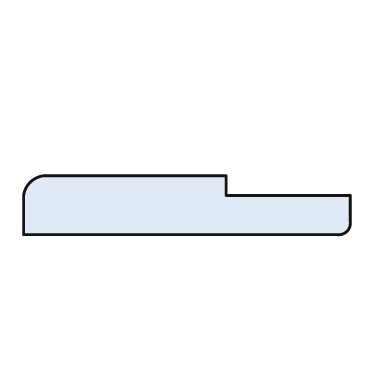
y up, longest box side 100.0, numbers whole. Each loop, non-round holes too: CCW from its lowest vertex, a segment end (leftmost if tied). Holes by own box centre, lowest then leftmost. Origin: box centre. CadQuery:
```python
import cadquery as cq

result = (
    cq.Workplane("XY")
    .moveTo(-50.0, -9.0)
    .lineTo(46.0, -9.0)
    .threePointArc((49.0, -8.0), (50.0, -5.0))
    .lineTo(50.0, 3.0)
    .lineTo(12.0, 3.0)
    .lineTo(12.0, 9.0)
    .lineTo(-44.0, 9.0)
    .threePointArc((-48.0, 7.0), (-50.0, 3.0))
    .close()
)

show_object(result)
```